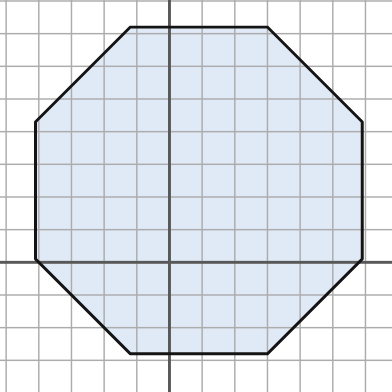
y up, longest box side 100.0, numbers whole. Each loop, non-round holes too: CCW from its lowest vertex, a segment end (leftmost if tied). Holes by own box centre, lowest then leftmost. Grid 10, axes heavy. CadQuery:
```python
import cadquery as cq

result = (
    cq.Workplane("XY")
    .moveTo(-12.0, -28.0)
    .lineTo(30.0, -28.0)
    .lineTo(59.0, 1.0)
    .lineTo(59.0, 43.0)
    .lineTo(30.0, 72.0)
    .lineTo(-12.0, 72.0)
    .lineTo(-41.0, 43.0)
    .lineTo(-41.0, 1.0)
    .close()
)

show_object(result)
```